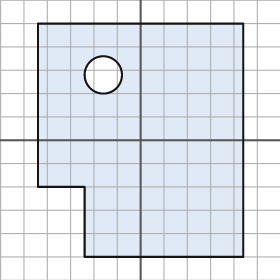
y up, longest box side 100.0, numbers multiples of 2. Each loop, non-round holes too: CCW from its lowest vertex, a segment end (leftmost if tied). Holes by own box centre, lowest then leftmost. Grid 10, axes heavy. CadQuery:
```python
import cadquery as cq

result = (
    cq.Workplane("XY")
    .moveTo(-24.0, -50.0)
    .lineTo(44.0, -50.0)
    .lineTo(44.0, 50.0)
    .lineTo(-44.0, 50.0)
    .lineTo(-44.0, -20.0)
    .lineTo(-24.0, -20.0)
    .close()
    .moveTo(-16.0, 28.0)
    .circle(8.0)
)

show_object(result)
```